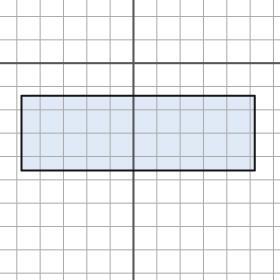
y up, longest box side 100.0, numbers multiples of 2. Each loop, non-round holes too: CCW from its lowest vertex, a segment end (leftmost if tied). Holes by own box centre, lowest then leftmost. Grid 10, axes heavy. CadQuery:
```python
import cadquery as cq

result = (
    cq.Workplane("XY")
    .moveTo(-48.0, -46.0)
    .lineTo(52.0, -46.0)
    .lineTo(52.0, -14.0)
    .lineTo(-48.0, -14.0)
    .close()
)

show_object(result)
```